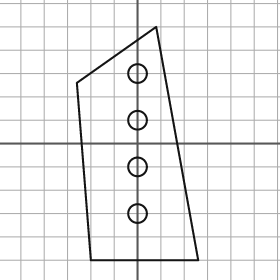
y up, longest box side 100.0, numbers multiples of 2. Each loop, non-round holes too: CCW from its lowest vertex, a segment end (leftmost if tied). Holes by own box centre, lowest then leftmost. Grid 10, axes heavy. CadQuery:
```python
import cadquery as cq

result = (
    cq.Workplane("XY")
    .moveTo(-20.0, -50.0)
    .lineTo(26.0, -50.0)
    .lineTo(8.0, 50.0)
    .lineTo(-26.0, 26.0)
    .close()
    .moveTo(0.0, -30.0)
    .circle(4.0)
    .moveTo(0.0, -10.0)
    .circle(4.0)
    .moveTo(0.0, 10.0)
    .circle(4.0)
    .moveTo(0.0, 30.0)
    .circle(4.0)
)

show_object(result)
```